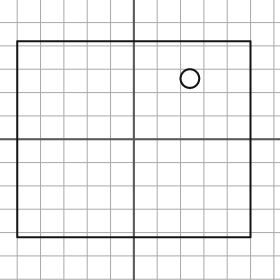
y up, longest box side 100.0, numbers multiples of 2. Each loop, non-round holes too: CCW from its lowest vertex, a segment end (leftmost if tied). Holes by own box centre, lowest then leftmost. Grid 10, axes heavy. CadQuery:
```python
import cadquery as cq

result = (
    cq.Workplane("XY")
    .moveTo(-50.0, -42.0)
    .lineTo(50.0, -42.0)
    .lineTo(50.0, 42.0)
    .lineTo(-50.0, 42.0)
    .close()
    .moveTo(24.0, 26.0)
    .circle(4.0)
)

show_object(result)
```